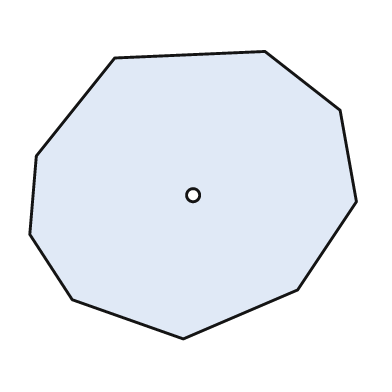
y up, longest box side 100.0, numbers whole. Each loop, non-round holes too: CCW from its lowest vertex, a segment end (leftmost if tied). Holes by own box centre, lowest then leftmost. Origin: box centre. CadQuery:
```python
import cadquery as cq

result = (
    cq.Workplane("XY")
    .moveTo(-3.0, -44.0)
    .lineTo(32.0, -29.0)
    .lineTo(50.0, -2.0)
    .lineTo(45.0, 26.0)
    .lineTo(22.0, 44.0)
    .lineTo(-24.0, 42.0)
    .lineTo(-48.0, 12.0)
    .lineTo(-50.0, -12.0)
    .lineTo(-37.0, -32.0)
    .close()
    .moveTo(0.0, 0.0)
    .circle(2.0)
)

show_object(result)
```